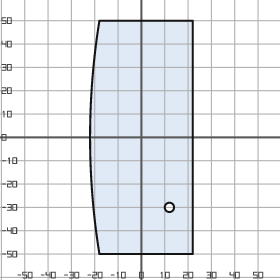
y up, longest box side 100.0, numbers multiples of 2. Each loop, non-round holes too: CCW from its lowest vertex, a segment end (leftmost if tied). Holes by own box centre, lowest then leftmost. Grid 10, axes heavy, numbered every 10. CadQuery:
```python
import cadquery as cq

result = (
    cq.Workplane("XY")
    .moveTo(-18.0, -50.0)
    .lineTo(22.0, -50.0)
    .lineTo(22.0, 50.0)
    .lineTo(-18.0, 50.0)
    .threePointArc((-22.0, 0.0), (-18.0, -50.0))
    .close()
    .moveTo(12.0, -30.0)
    .circle(2.0)
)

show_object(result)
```